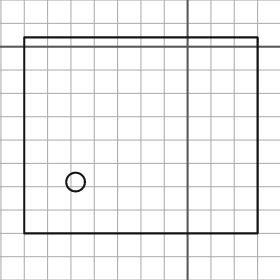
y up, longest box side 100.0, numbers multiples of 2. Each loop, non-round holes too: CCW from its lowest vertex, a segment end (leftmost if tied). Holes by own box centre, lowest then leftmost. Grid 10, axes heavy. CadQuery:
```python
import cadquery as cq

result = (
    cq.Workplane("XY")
    .moveTo(-70.0, -80.0)
    .lineTo(30.0, -80.0)
    .lineTo(30.0, 4.0)
    .lineTo(-70.0, 4.0)
    .close()
    .moveTo(-48.0, -58.0)
    .circle(4.0)
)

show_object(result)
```